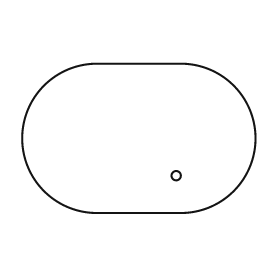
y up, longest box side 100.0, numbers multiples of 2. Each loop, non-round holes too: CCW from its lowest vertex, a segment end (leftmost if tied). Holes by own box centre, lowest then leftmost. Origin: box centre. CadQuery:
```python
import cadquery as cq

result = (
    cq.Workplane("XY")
    .moveTo(-18.0, -32.0)
    .lineTo(18.0, -32.0)
    .threePointArc((50.0, 0.0), (18.0, 32.0))
    .lineTo(-18.0, 32.0)
    .threePointArc((-50.0, 0.0), (-18.0, -32.0))
    .close()
    .moveTo(16.0, -16.0)
    .circle(2.0)
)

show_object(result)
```